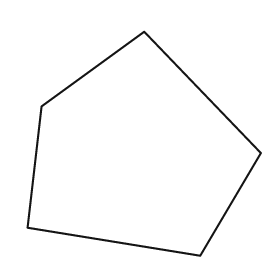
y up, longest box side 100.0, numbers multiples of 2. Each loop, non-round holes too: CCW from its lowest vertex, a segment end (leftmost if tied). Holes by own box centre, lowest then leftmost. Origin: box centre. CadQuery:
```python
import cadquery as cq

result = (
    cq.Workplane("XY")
    .moveTo(24.0, -48.0)
    .lineTo(50.0, -4.0)
    .lineTo(0.0, 48.0)
    .lineTo(-44.0, 16.0)
    .lineTo(-50.0, -36.0)
    .close()
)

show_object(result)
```